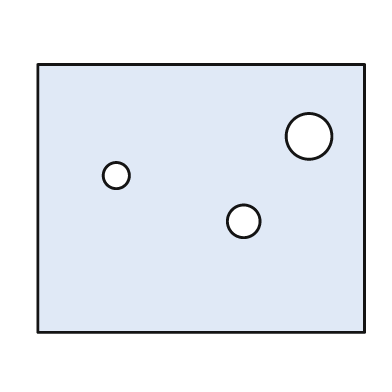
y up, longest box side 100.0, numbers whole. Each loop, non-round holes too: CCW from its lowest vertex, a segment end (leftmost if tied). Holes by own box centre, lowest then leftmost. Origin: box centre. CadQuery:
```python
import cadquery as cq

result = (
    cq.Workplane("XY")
    .moveTo(-50.0, -41.0)
    .lineTo(50.0, -41.0)
    .lineTo(50.0, 41.0)
    .lineTo(-50.0, 41.0)
    .close()
    .moveTo(13.0, -7.0)
    .circle(5.0)
    .moveTo(-26.0, 7.0)
    .circle(4.0)
    .moveTo(33.0, 19.0)
    .circle(7.0)
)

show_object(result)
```